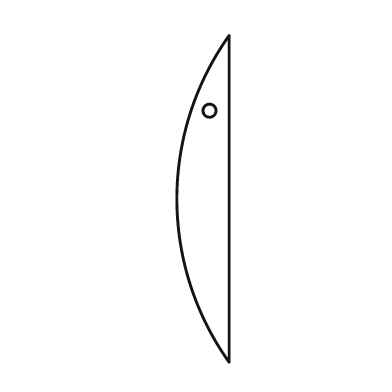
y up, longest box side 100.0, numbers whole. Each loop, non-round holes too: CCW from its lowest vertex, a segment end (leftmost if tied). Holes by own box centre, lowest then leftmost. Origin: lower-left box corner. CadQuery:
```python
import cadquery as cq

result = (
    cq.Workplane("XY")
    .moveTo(16.0, 0.0)
    .lineTo(16.0, 100.0)
    .threePointArc((0.0, 50.0), (16.0, 0.0))
    .close()
    .moveTo(10.0, 77.0)
    .circle(2.0)
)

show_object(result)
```